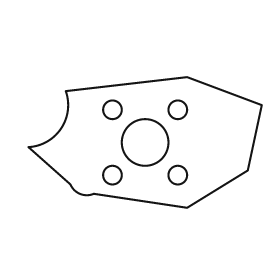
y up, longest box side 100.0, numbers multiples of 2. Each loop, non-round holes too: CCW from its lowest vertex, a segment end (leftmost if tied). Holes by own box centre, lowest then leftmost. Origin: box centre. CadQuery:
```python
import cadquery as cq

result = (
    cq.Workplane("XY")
    .moveTo(18.0, -28.0)
    .lineTo(44.0, -12.0)
    .lineTo(50.0, 16.0)
    .lineTo(18.0, 28.0)
    .lineTo(-34.0, 22.0)
    .threePointArc((-36.0, 6.0), (-50.0, -2.0))
    .lineTo(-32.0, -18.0)
    .threePointArc((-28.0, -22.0), (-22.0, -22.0))
    .close()
    .moveTo(-14.0, -14.0)
    .circle(4.0)
    .moveTo(14.0, -14.0)
    .circle(4.0)
    .moveTo(0.0, 0.0)
    .circle(10.0)
    .moveTo(-14.0, 14.0)
    .circle(4.0)
    .moveTo(14.0, 14.0)
    .circle(4.0)
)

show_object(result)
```